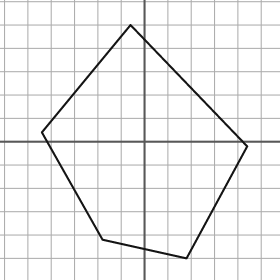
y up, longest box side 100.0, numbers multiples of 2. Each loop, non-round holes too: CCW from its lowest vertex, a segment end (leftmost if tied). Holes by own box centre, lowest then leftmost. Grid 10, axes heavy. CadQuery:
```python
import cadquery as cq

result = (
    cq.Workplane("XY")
    .moveTo(18.0, -50.0)
    .lineTo(44.0, -2.0)
    .lineTo(-6.0, 50.0)
    .lineTo(-44.0, 4.0)
    .lineTo(-18.0, -42.0)
    .close()
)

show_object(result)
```